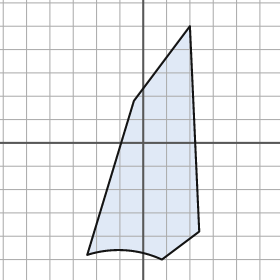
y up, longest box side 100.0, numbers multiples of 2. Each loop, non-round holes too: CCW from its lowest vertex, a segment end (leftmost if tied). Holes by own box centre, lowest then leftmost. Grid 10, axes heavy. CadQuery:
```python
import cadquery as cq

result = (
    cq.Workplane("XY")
    .moveTo(8.0, -50.0)
    .lineTo(24.0, -38.0)
    .lineTo(20.0, 50.0)
    .lineTo(-4.0, 18.0)
    .lineTo(-24.0, -48.0)
    .threePointArc((-8.0, -46.0), (8.0, -50.0))
    .close()
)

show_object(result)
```